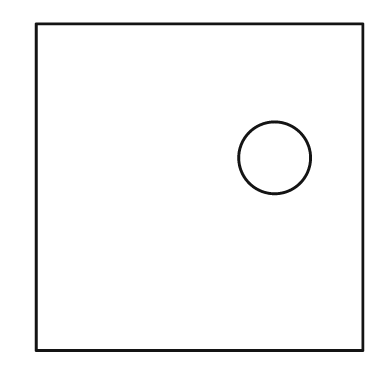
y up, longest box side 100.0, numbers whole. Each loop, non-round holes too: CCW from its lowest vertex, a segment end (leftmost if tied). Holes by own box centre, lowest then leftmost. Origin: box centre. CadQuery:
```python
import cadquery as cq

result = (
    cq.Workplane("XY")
    .moveTo(-50.0, -50.0)
    .lineTo(50.0, -50.0)
    .lineTo(50.0, 50.0)
    .lineTo(-50.0, 50.0)
    .close()
    .moveTo(23.0, 9.0)
    .circle(11.0)
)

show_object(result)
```